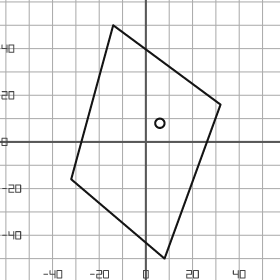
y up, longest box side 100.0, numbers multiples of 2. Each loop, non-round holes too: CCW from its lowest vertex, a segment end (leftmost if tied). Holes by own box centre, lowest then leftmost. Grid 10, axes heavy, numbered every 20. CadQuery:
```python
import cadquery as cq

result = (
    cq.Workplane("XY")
    .moveTo(8.0, -50.0)
    .lineTo(32.0, 16.0)
    .lineTo(-14.0, 50.0)
    .lineTo(-32.0, -16.0)
    .close()
    .moveTo(6.0, 8.0)
    .circle(2.0)
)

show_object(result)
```